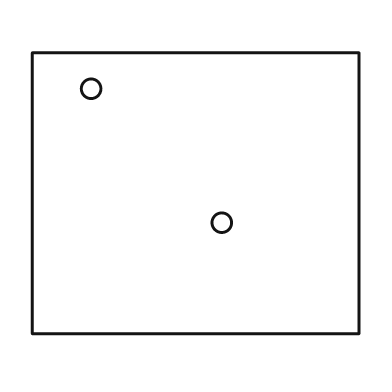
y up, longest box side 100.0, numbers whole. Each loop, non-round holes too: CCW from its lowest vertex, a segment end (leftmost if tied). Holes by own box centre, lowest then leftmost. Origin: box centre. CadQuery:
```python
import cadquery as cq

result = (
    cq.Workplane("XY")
    .moveTo(-50.0, -43.0)
    .lineTo(50.0, -43.0)
    .lineTo(50.0, 43.0)
    .lineTo(-50.0, 43.0)
    .close()
    .moveTo(8.0, -9.0)
    .circle(3.0)
    .moveTo(-32.0, 32.0)
    .circle(3.0)
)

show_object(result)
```